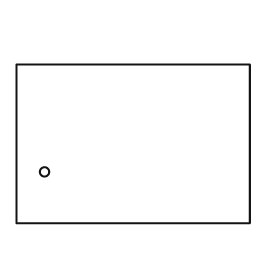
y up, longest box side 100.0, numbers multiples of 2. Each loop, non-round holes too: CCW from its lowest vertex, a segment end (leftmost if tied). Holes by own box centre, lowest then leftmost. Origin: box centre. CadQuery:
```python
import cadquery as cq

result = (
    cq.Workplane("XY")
    .moveTo(-50.0, -34.0)
    .lineTo(50.0, -34.0)
    .lineTo(50.0, 34.0)
    .lineTo(-50.0, 34.0)
    .close()
    .moveTo(-38.0, -12.0)
    .circle(2.0)
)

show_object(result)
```